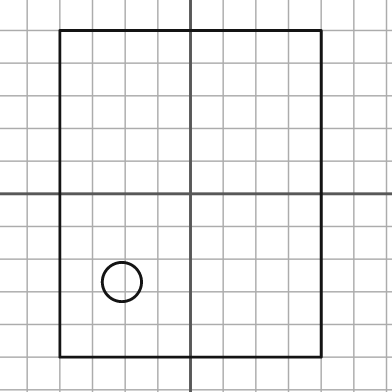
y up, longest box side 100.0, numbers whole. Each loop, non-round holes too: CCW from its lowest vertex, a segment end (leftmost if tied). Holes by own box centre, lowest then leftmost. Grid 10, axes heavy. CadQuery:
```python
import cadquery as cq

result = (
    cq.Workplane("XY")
    .moveTo(-40.0, -50.0)
    .lineTo(40.0, -50.0)
    .lineTo(40.0, 50.0)
    .lineTo(-40.0, 50.0)
    .close()
    .moveTo(-21.0, -27.0)
    .circle(6.0)
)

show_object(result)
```